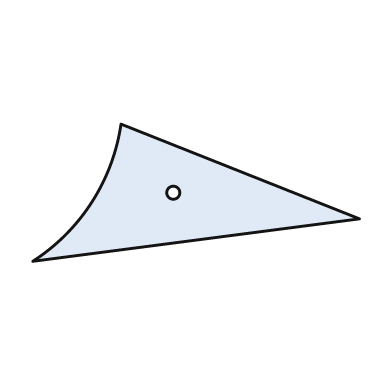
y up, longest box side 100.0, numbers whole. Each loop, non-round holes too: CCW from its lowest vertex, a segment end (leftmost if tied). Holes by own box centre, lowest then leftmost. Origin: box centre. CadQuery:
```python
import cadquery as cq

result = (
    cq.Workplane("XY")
    .moveTo(-50.0, -21.0)
    .lineTo(50.0, -8.0)
    .lineTo(-23.0, 21.0)
    .threePointArc((-32.0, -3.0), (-50.0, -21.0))
    .close()
    .moveTo(-7.0, 0.0)
    .circle(2.0)
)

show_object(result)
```